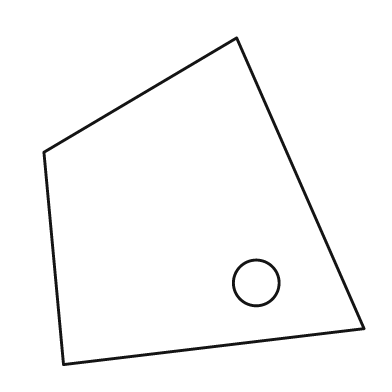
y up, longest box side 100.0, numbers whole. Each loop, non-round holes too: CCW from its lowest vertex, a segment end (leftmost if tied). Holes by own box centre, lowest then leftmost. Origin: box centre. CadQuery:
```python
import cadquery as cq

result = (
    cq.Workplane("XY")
    .moveTo(-43.0, -50.0)
    .lineTo(49.0, -39.0)
    .lineTo(10.0, 50.0)
    .lineTo(-49.0, 15.0)
    .close()
    .moveTo(16.0, -25.0)
    .circle(7.0)
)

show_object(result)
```